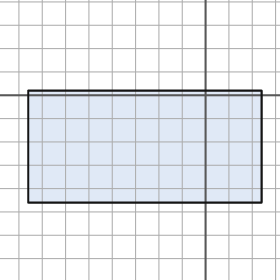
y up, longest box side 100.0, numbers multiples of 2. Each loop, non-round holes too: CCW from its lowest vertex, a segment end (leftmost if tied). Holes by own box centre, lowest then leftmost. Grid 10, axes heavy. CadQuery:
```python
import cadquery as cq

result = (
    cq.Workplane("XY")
    .moveTo(-76.0, -46.0)
    .lineTo(24.0, -46.0)
    .lineTo(24.0, 2.0)
    .lineTo(-76.0, 2.0)
    .close()
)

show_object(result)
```